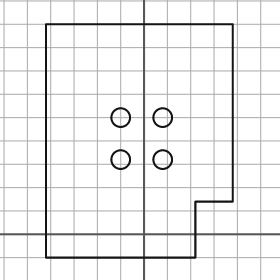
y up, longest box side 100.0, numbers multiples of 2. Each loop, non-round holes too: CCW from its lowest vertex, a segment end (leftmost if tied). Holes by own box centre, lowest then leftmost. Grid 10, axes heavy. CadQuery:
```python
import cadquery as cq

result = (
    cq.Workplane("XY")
    .moveTo(-42.0, -10.0)
    .lineTo(22.0, -10.0)
    .lineTo(22.0, 14.0)
    .lineTo(38.0, 14.0)
    .lineTo(38.0, 90.0)
    .lineTo(-42.0, 90.0)
    .close()
    .moveTo(-10.0, 32.0)
    .circle(4.0)
    .moveTo(8.0, 32.0)
    .circle(4.0)
    .moveTo(-10.0, 50.0)
    .circle(4.0)
    .moveTo(8.0, 50.0)
    .circle(4.0)
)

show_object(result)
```